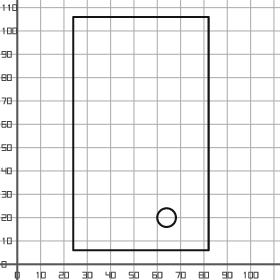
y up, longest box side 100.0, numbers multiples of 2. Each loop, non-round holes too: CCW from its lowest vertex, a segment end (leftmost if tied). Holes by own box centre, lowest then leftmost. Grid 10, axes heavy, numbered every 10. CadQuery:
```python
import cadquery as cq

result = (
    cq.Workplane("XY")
    .moveTo(24.0, 6.0)
    .lineTo(82.0, 6.0)
    .lineTo(82.0, 106.0)
    .lineTo(24.0, 106.0)
    .close()
    .moveTo(64.0, 20.0)
    .circle(4.0)
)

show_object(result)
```